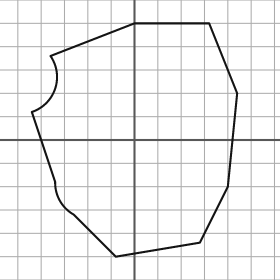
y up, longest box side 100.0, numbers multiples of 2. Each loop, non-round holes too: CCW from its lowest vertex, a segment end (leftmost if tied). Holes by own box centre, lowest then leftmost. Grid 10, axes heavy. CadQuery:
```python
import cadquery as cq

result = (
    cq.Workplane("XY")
    .moveTo(-8.0, -50.0)
    .lineTo(28.0, -44.0)
    .lineTo(40.0, -20.0)
    .lineTo(44.0, 20.0)
    .lineTo(32.0, 50.0)
    .lineTo(0.0, 50.0)
    .lineTo(-36.0, 36.0)
    .threePointArc((-34.0, 22.0), (-44.0, 12.0))
    .lineTo(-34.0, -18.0)
    .threePointArc((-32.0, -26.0), (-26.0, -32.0))
    .close()
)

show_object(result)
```